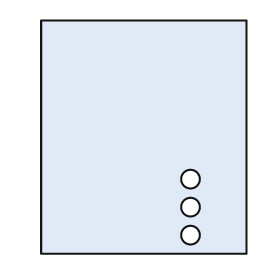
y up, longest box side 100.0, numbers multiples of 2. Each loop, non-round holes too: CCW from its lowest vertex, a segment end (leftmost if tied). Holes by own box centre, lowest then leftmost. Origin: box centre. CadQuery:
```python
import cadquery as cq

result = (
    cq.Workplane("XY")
    .moveTo(-44.0, -50.0)
    .lineTo(44.0, -50.0)
    .lineTo(44.0, 50.0)
    .lineTo(-44.0, 50.0)
    .close()
    .moveTo(20.0, -42.0)
    .circle(4.0)
    .moveTo(20.0, -30.0)
    .circle(4.0)
    .moveTo(20.0, -18.0)
    .circle(4.0)
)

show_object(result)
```